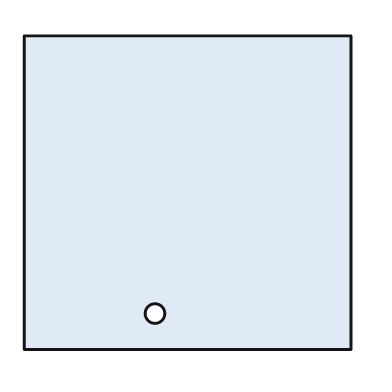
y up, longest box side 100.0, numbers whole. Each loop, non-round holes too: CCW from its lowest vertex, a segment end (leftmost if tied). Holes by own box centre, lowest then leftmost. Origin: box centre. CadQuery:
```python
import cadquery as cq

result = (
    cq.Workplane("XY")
    .moveTo(-50.0, -48.0)
    .lineTo(50.0, -48.0)
    .lineTo(50.0, 48.0)
    .lineTo(-50.0, 48.0)
    .close()
    .moveTo(-10.0, -37.0)
    .circle(3.0)
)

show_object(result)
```